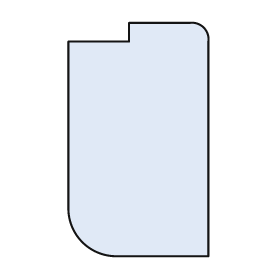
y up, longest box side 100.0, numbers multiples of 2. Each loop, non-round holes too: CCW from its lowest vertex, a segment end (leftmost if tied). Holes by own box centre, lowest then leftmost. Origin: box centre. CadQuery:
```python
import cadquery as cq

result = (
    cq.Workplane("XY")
    .moveTo(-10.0, -50.0)
    .lineTo(30.0, -50.0)
    .lineTo(30.0, 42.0)
    .threePointArc((28.0, 48.0), (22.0, 50.0))
    .lineTo(-4.0, 50.0)
    .lineTo(-4.0, 42.0)
    .lineTo(-30.0, 42.0)
    .lineTo(-30.0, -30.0)
    .threePointArc((-24.0, -44.0), (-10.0, -50.0))
    .close()
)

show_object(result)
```